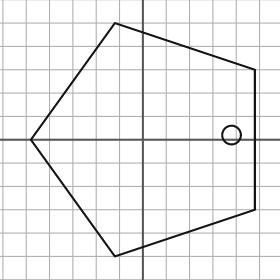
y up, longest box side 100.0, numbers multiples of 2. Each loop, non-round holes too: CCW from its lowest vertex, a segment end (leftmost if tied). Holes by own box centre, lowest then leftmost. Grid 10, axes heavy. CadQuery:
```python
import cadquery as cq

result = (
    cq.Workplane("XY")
    .moveTo(-12.0, -50.0)
    .lineTo(48.0, -30.0)
    .lineTo(48.0, 30.0)
    .lineTo(-12.0, 50.0)
    .lineTo(-48.0, 0.0)
    .close()
    .moveTo(38.0, 2.0)
    .circle(4.0)
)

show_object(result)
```